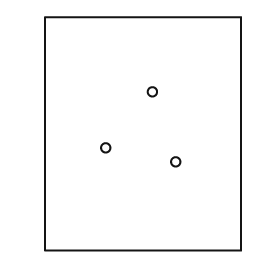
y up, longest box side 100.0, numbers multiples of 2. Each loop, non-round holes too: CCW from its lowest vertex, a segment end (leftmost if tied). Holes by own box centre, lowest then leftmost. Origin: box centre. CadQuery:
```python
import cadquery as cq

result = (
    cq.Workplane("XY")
    .moveTo(-42.0, -50.0)
    .lineTo(42.0, -50.0)
    .lineTo(42.0, 50.0)
    .lineTo(-42.0, 50.0)
    .close()
    .moveTo(14.0, -12.0)
    .circle(2.0)
    .moveTo(-16.0, -6.0)
    .circle(2.0)
    .moveTo(4.0, 18.0)
    .circle(2.0)
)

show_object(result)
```